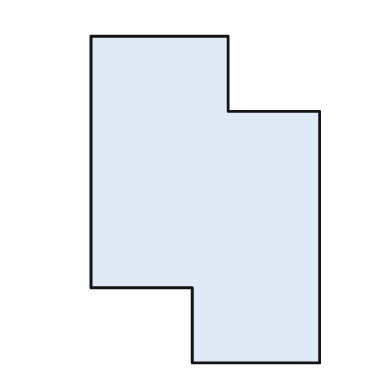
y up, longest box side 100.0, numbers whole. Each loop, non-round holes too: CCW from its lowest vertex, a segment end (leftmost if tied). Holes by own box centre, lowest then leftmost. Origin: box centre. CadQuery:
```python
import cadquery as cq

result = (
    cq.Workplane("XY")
    .moveTo(-4.0, -50.0)
    .lineTo(35.0, -50.0)
    .lineTo(35.0, 27.0)
    .lineTo(7.0, 27.0)
    .lineTo(7.0, 50.0)
    .lineTo(-35.0, 50.0)
    .lineTo(-35.0, -27.0)
    .lineTo(-4.0, -27.0)
    .close()
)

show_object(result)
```